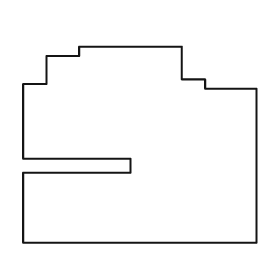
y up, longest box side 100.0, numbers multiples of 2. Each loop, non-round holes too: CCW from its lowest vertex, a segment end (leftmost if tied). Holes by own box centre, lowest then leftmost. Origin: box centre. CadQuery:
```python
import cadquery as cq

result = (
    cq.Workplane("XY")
    .moveTo(-50.0, -42.0)
    .lineTo(50.0, -42.0)
    .lineTo(50.0, 24.0)
    .lineTo(28.0, 24.0)
    .lineTo(28.0, 28.0)
    .lineTo(18.0, 28.0)
    .lineTo(18.0, 42.0)
    .lineTo(-26.0, 42.0)
    .lineTo(-26.0, 38.0)
    .lineTo(-40.0, 38.0)
    .lineTo(-40.0, 26.0)
    .lineTo(-50.0, 26.0)
    .lineTo(-50.0, -6.0)
    .lineTo(-4.0, -6.0)
    .lineTo(-4.0, -12.0)
    .lineTo(-50.0, -12.0)
    .close()
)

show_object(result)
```